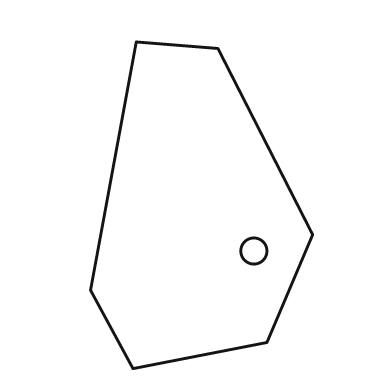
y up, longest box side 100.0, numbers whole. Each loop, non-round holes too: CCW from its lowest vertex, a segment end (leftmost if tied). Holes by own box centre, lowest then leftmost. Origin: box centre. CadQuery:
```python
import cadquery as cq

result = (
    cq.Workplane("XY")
    .moveTo(-21.0, -50.0)
    .lineTo(20.0, -42.0)
    .lineTo(34.0, -9.0)
    .lineTo(5.0, 48.0)
    .lineTo(-20.0, 50.0)
    .lineTo(-34.0, -26.0)
    .close()
    .moveTo(16.0, -14.0)
    .circle(4.0)
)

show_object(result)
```